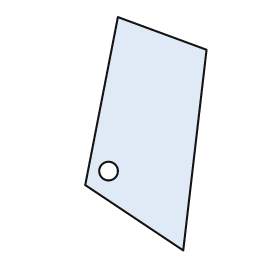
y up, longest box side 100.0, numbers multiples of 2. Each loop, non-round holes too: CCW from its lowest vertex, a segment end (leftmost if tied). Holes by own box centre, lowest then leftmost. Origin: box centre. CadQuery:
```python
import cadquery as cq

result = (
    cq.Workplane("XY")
    .moveTo(16.0, -50.0)
    .lineTo(26.0, 36.0)
    .lineTo(-12.0, 50.0)
    .lineTo(-26.0, -22.0)
    .close()
    .moveTo(-16.0, -16.0)
    .circle(4.0)
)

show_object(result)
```